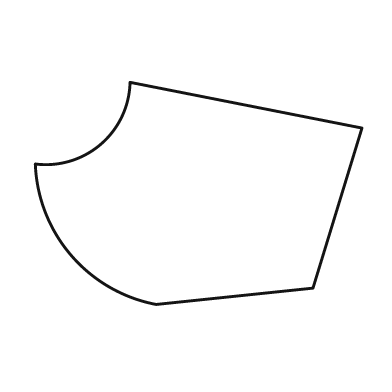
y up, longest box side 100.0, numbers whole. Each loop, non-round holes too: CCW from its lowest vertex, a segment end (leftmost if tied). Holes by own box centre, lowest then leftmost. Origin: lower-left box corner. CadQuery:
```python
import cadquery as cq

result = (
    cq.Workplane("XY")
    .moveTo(37.0, 0.0)
    .lineTo(85.0, 5.0)
    .lineTo(100.0, 54.0)
    .lineTo(29.0, 68.0)
    .threePointArc((20.0, 49.0), (0.0, 43.0))
    .threePointArc((11.0, 15.0), (37.0, 0.0))
    .close()
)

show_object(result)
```